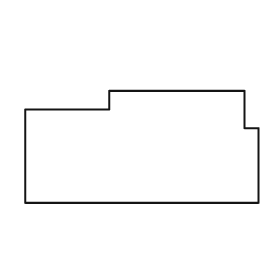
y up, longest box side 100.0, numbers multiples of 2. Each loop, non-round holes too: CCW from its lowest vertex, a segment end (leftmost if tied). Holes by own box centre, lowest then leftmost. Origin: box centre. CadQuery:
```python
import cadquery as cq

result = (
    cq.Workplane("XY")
    .moveTo(-50.0, -24.0)
    .lineTo(50.0, -24.0)
    .lineTo(50.0, 8.0)
    .lineTo(44.0, 8.0)
    .lineTo(44.0, 24.0)
    .lineTo(-14.0, 24.0)
    .lineTo(-14.0, 16.0)
    .lineTo(-50.0, 16.0)
    .close()
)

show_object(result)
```